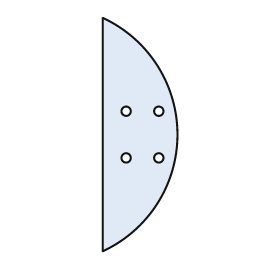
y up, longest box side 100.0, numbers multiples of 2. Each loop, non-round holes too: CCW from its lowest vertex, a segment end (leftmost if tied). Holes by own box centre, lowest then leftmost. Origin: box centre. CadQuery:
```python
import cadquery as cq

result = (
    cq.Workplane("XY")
    .moveTo(-16.0, -50.0)
    .threePointArc((16.0, 0.0), (-16.0, 50.0))
    .close()
    .moveTo(-6.0, -10.0)
    .circle(2.0)
    .moveTo(8.0, -10.0)
    .circle(2.0)
    .moveTo(-6.0, 10.0)
    .circle(2.0)
    .moveTo(8.0, 10.0)
    .circle(2.0)
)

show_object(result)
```